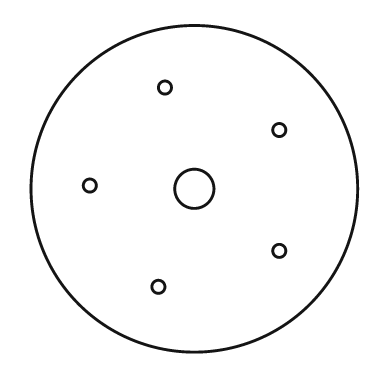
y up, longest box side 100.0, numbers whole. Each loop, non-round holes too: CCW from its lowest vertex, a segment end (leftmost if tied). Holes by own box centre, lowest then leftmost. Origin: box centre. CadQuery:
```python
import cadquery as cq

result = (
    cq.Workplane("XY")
    .moveTo(0.0, 0.0)
    .circle(50.0)
    .moveTo(-11.0, -30.0)
    .circle(2.0)
    .moveTo(26.0, -19.0)
    .circle(2.0)
    .moveTo(0.0, 0.0)
    .circle(6.0)
    .moveTo(-32.0, 1.0)
    .circle(2.0)
    .moveTo(26.0, 18.0)
    .circle(2.0)
    .moveTo(-9.0, 31.0)
    .circle(2.0)
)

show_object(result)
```